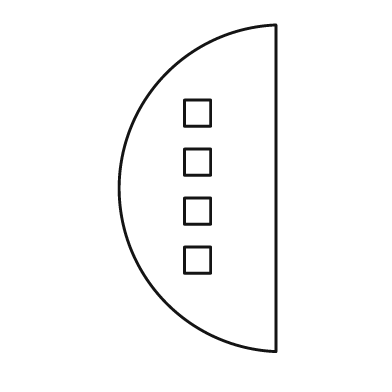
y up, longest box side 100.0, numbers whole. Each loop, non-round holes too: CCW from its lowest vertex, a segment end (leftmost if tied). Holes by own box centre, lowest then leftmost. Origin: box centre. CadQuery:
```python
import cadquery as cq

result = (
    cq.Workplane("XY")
    .moveTo(24.0, -50.0)
    .lineTo(24.0, 50.0)
    .threePointArc((-24.0, 0.0), (24.0, -50.0))
    .close()
    .moveTo(-4.0, -26.0)
    .lineTo(4.0, -26.0)
    .lineTo(4.0, -18.0)
    .lineTo(-4.0, -18.0)
    .close()
    .moveTo(-4.0, -11.0)
    .lineTo(4.0, -11.0)
    .lineTo(4.0, -3.0)
    .lineTo(-4.0, -3.0)
    .close()
    .moveTo(-4.0, 4.0)
    .lineTo(4.0, 4.0)
    .lineTo(4.0, 12.0)
    .lineTo(-4.0, 12.0)
    .close()
    .moveTo(-4.0, 19.0)
    .lineTo(4.0, 19.0)
    .lineTo(4.0, 27.0)
    .lineTo(-4.0, 27.0)
    .close()
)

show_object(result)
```